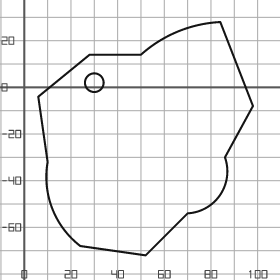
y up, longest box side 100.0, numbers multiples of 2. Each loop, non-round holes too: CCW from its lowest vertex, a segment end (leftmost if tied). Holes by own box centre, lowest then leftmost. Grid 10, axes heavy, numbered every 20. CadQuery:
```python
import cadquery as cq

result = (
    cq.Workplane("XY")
    .moveTo(52.0, -72.0)
    .lineTo(70.0, -54.0)
    .threePointArc((84.0, -46.0), (86.0, -30.0))
    .lineTo(98.0, -8.0)
    .lineTo(84.0, 28.0)
    .threePointArc((66.0, 24.0), (50.0, 14.0))
    .lineTo(28.0, 14.0)
    .lineTo(6.0, -4.0)
    .lineTo(10.0, -32.0)
    .threePointArc((12.0, -52.0), (24.0, -68.0))
    .close()
    .moveTo(30.0, 2.0)
    .circle(4.0)
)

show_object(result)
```